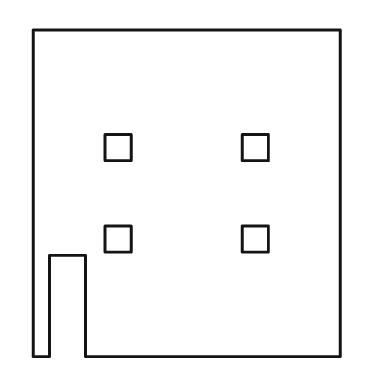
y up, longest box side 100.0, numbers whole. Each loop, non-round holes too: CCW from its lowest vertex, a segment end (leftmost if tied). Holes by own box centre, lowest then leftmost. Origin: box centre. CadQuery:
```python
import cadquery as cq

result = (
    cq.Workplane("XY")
    .moveTo(-47.0, -50.0)
    .lineTo(-42.0, -50.0)
    .lineTo(-42.0, -19.0)
    .lineTo(-31.0, -19.0)
    .lineTo(-31.0, -50.0)
    .lineTo(47.0, -50.0)
    .lineTo(47.0, 50.0)
    .lineTo(-47.0, 50.0)
    .close()
    .moveTo(-25.0, -18.0)
    .lineTo(-17.0, -18.0)
    .lineTo(-17.0, -10.0)
    .lineTo(-25.0, -10.0)
    .close()
    .moveTo(17.0, -18.0)
    .lineTo(25.0, -18.0)
    .lineTo(25.0, -10.0)
    .lineTo(17.0, -10.0)
    .close()
    .moveTo(-25.0, 10.0)
    .lineTo(-17.0, 10.0)
    .lineTo(-17.0, 18.0)
    .lineTo(-25.0, 18.0)
    .close()
    .moveTo(17.0, 10.0)
    .lineTo(25.0, 10.0)
    .lineTo(25.0, 18.0)
    .lineTo(17.0, 18.0)
    .close()
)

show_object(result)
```